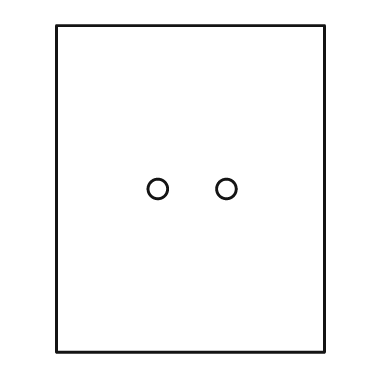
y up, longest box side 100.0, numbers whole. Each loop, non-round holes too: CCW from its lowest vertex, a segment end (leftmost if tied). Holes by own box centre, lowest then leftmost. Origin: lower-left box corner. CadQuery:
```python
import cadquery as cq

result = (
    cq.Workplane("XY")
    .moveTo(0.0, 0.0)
    .lineTo(82.0, 0.0)
    .lineTo(82.0, 100.0)
    .lineTo(0.0, 100.0)
    .close()
    .moveTo(31.0, 50.0)
    .circle(3.0)
    .moveTo(52.0, 50.0)
    .circle(3.0)
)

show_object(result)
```